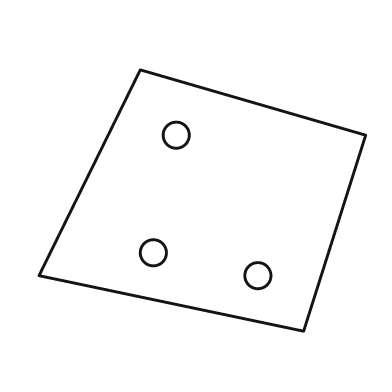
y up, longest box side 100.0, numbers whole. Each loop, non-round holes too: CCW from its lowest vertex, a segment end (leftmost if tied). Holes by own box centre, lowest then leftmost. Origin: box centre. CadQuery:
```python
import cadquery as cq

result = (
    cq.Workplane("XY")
    .moveTo(31.0, -40.0)
    .lineTo(50.0, 20.0)
    .lineTo(-19.0, 40.0)
    .lineTo(-50.0, -23.0)
    .close()
    .moveTo(17.0, -23.0)
    .circle(4.0)
    .moveTo(-15.0, -16.0)
    .circle(4.0)
    .moveTo(-8.0, 20.0)
    .circle(4.0)
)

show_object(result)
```